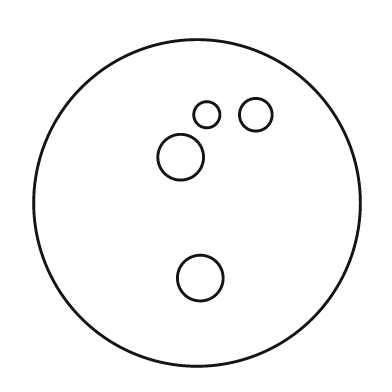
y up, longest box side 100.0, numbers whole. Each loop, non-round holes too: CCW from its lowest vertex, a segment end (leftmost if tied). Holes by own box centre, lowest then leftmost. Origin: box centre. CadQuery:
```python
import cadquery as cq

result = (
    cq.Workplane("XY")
    .moveTo(0.0, 0.0)
    .circle(50.0)
    .moveTo(1.0, -23.0)
    .circle(7.0)
    .moveTo(-5.0, 14.0)
    .circle(7.0)
    .moveTo(3.0, 27.0)
    .circle(4.0)
    .moveTo(18.0, 27.0)
    .circle(5.0)
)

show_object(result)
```